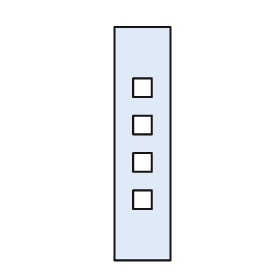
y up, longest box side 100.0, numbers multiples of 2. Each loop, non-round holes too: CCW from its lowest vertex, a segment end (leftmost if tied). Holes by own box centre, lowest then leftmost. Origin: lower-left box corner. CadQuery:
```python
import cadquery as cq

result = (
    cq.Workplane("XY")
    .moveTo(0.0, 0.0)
    .lineTo(24.0, 0.0)
    .lineTo(24.0, 100.0)
    .lineTo(0.0, 100.0)
    .close()
    .moveTo(8.0, 22.0)
    .lineTo(16.0, 22.0)
    .lineTo(16.0, 30.0)
    .lineTo(8.0, 30.0)
    .close()
    .moveTo(8.0, 38.0)
    .lineTo(16.0, 38.0)
    .lineTo(16.0, 46.0)
    .lineTo(8.0, 46.0)
    .close()
    .moveTo(8.0, 54.0)
    .lineTo(16.0, 54.0)
    .lineTo(16.0, 62.0)
    .lineTo(8.0, 62.0)
    .close()
    .moveTo(8.0, 70.0)
    .lineTo(16.0, 70.0)
    .lineTo(16.0, 78.0)
    .lineTo(8.0, 78.0)
    .close()
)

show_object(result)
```